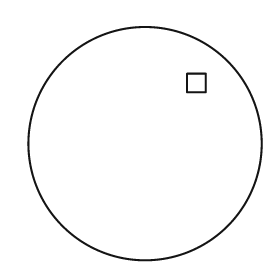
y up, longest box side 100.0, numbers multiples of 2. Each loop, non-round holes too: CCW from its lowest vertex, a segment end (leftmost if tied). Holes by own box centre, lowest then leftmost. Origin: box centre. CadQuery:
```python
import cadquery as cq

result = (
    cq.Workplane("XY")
    .moveTo(0.0, 0.0)
    .circle(50.0)
    .moveTo(18.0, 22.0)
    .lineTo(26.0, 22.0)
    .lineTo(26.0, 30.0)
    .lineTo(18.0, 30.0)
    .close()
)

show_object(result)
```